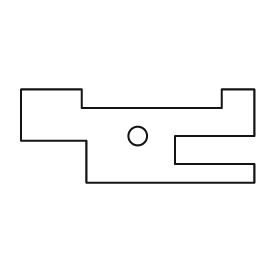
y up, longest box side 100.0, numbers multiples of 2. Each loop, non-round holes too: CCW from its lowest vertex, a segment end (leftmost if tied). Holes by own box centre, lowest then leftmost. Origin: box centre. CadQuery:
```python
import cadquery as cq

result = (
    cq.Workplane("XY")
    .moveTo(-22.0, -20.0)
    .lineTo(50.0, -20.0)
    .lineTo(50.0, -12.0)
    .lineTo(16.0, -12.0)
    .lineTo(16.0, 0.0)
    .lineTo(50.0, 0.0)
    .lineTo(50.0, 20.0)
    .lineTo(36.0, 20.0)
    .lineTo(36.0, 12.0)
    .lineTo(-24.0, 12.0)
    .lineTo(-24.0, 20.0)
    .lineTo(-50.0, 20.0)
    .lineTo(-50.0, -2.0)
    .lineTo(-22.0, -2.0)
    .close()
    .moveTo(0.0, 0.0)
    .circle(4.0)
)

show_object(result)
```